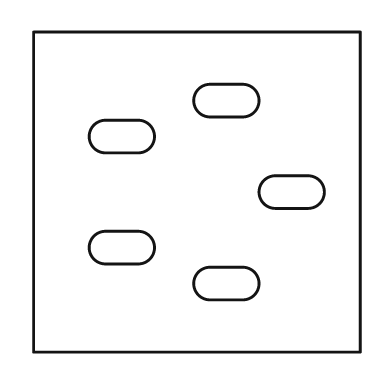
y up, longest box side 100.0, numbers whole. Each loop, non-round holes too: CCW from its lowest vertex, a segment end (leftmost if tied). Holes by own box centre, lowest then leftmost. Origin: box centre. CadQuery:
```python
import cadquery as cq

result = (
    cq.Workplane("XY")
    .moveTo(-50.0, -49.0)
    .lineTo(50.0, -49.0)
    .lineTo(50.0, 49.0)
    .lineTo(-50.0, 49.0)
    .close()
    .moveTo(4.0, -33.0)
    .lineTo(14.0, -33.0)
    .threePointArc((19.0, -28.0), (14.0, -23.0))
    .lineTo(4.0, -23.0)
    .threePointArc((-1.0, -28.0), (4.0, -33.0))
    .close()
    .moveTo(-28.0, -22.0)
    .lineTo(-18.0, -22.0)
    .threePointArc((-13.0, -17.0), (-18.0, -12.0))
    .lineTo(-28.0, -12.0)
    .threePointArc((-33.0, -17.0), (-28.0, -22.0))
    .close()
    .moveTo(24.0, -5.0)
    .lineTo(34.0, -5.0)
    .threePointArc((39.0, 0.0), (34.0, 5.0))
    .lineTo(24.0, 5.0)
    .threePointArc((19.0, 0.0), (24.0, -5.0))
    .close()
    .moveTo(-28.0, 12.0)
    .lineTo(-18.0, 12.0)
    .threePointArc((-13.0, 17.0), (-18.0, 22.0))
    .lineTo(-28.0, 22.0)
    .threePointArc((-33.0, 17.0), (-28.0, 12.0))
    .close()
    .moveTo(4.0, 23.0)
    .lineTo(14.0, 23.0)
    .threePointArc((19.0, 28.0), (14.0, 33.0))
    .lineTo(4.0, 33.0)
    .threePointArc((-1.0, 28.0), (4.0, 23.0))
    .close()
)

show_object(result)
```